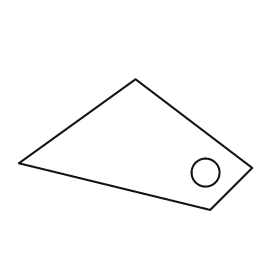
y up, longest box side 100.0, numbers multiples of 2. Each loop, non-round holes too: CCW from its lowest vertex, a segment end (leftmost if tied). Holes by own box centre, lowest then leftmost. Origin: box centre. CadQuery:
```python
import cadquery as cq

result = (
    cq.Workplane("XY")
    .moveTo(32.0, -28.0)
    .lineTo(50.0, -10.0)
    .lineTo(0.0, 28.0)
    .lineTo(-50.0, -8.0)
    .close()
    .moveTo(30.0, -12.0)
    .circle(6.0)
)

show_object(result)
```